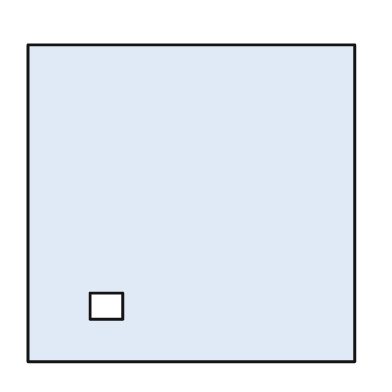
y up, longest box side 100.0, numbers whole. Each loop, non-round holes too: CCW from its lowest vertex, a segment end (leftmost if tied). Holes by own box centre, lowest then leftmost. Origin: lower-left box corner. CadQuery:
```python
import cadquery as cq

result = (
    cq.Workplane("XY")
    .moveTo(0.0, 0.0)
    .lineTo(100.0, 0.0)
    .lineTo(100.0, 97.0)
    .lineTo(0.0, 97.0)
    .close()
    .moveTo(19.0, 13.0)
    .lineTo(29.0, 13.0)
    .lineTo(29.0, 21.0)
    .lineTo(19.0, 21.0)
    .close()
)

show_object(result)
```